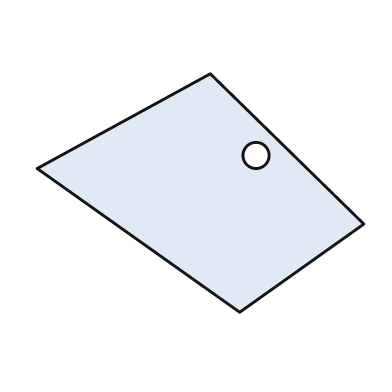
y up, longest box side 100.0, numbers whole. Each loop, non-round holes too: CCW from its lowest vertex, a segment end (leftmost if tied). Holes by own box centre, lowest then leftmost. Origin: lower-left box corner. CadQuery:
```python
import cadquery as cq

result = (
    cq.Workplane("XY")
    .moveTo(62.0, 0.0)
    .lineTo(100.0, 27.0)
    .lineTo(53.0, 73.0)
    .lineTo(0.0, 44.0)
    .close()
    .moveTo(67.0, 48.0)
    .circle(4.0)
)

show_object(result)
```